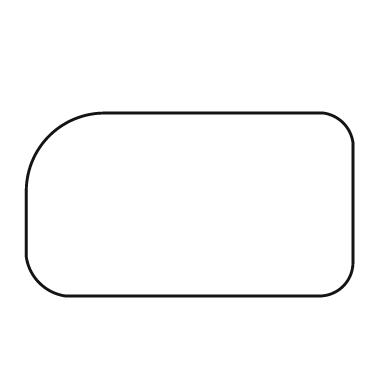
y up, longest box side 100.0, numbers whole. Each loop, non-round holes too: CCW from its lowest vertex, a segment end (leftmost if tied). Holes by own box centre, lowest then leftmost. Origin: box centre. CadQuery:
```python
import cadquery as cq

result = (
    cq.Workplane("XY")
    .moveTo(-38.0, -28.0)
    .lineTo(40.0, -28.0)
    .threePointArc((47.0, -25.0), (50.0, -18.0))
    .lineTo(50.0, 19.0)
    .threePointArc((47.0, 25.0), (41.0, 28.0))
    .lineTo(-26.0, 28.0)
    .threePointArc((-43.0, 21.0), (-50.0, 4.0))
    .lineTo(-50.0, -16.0)
    .threePointArc((-46.0, -24.0), (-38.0, -28.0))
    .close()
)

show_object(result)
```